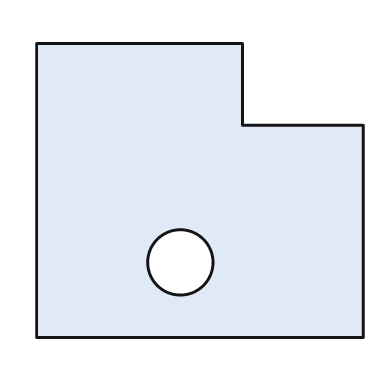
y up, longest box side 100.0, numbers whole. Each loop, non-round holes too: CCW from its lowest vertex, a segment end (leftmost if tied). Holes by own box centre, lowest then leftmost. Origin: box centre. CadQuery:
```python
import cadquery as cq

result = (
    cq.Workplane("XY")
    .moveTo(-50.0, -45.0)
    .lineTo(50.0, -45.0)
    .lineTo(50.0, 20.0)
    .lineTo(13.0, 20.0)
    .lineTo(13.0, 45.0)
    .lineTo(-50.0, 45.0)
    .close()
    .moveTo(-6.0, -22.0)
    .circle(10.0)
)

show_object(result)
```